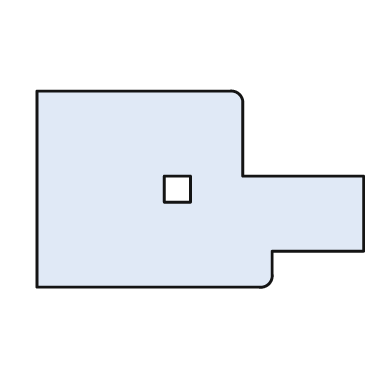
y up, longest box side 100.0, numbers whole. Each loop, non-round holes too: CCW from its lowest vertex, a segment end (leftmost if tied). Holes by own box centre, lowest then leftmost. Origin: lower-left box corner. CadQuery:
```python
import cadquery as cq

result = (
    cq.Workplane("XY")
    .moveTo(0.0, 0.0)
    .lineTo(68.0, 0.0)
    .threePointArc((71.0, 1.0), (72.0, 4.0))
    .lineTo(72.0, 11.0)
    .lineTo(100.0, 11.0)
    .lineTo(100.0, 34.0)
    .lineTo(63.0, 34.0)
    .lineTo(63.0, 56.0)
    .threePointArc((62.0, 59.0), (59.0, 60.0))
    .lineTo(0.0, 60.0)
    .close()
    .moveTo(39.0, 26.0)
    .lineTo(47.0, 26.0)
    .lineTo(47.0, 34.0)
    .lineTo(39.0, 34.0)
    .close()
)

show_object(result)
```